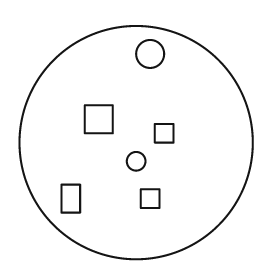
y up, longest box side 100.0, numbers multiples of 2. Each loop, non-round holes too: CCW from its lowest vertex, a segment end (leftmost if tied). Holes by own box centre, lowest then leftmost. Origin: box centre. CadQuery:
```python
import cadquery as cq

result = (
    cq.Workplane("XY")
    .moveTo(0.0, 0.0)
    .circle(50.0)
    .moveTo(-32.0, -30.0)
    .lineTo(-24.0, -30.0)
    .lineTo(-24.0, -18.0)
    .lineTo(-32.0, -18.0)
    .close()
    .moveTo(2.0, -28.0)
    .lineTo(10.0, -28.0)
    .lineTo(10.0, -20.0)
    .lineTo(2.0, -20.0)
    .close()
    .moveTo(0.0, -8.0)
    .circle(4.0)
    .moveTo(8.0, 0.0)
    .lineTo(16.0, 0.0)
    .lineTo(16.0, 8.0)
    .lineTo(8.0, 8.0)
    .close()
    .moveTo(-22.0, 4.0)
    .lineTo(-10.0, 4.0)
    .lineTo(-10.0, 16.0)
    .lineTo(-22.0, 16.0)
    .close()
    .moveTo(6.0, 38.0)
    .circle(6.0)
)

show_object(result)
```